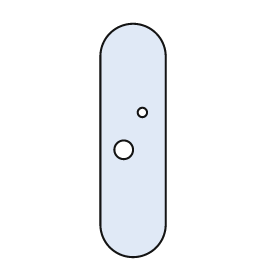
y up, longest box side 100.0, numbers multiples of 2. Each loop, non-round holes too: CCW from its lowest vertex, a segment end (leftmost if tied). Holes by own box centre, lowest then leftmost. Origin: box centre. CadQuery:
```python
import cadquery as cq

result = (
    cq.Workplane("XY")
    .moveTo(-14.0, -36.0)
    .threePointArc((0.0, -50.0), (14.0, -36.0))
    .lineTo(14.0, 36.0)
    .threePointArc((0.0, 50.0), (-14.0, 36.0))
    .close()
    .moveTo(-4.0, -4.0)
    .circle(4.0)
    .moveTo(4.0, 12.0)
    .circle(2.0)
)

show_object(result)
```